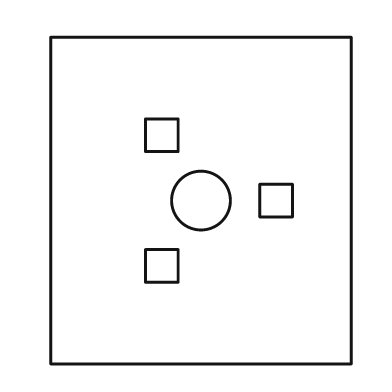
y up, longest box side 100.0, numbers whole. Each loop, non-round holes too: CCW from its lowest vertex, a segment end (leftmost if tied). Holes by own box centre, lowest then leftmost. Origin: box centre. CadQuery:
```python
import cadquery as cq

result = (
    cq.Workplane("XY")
    .moveTo(-46.0, -50.0)
    .lineTo(46.0, -50.0)
    .lineTo(46.0, 50.0)
    .lineTo(-46.0, 50.0)
    .close()
    .moveTo(-17.0, -25.0)
    .lineTo(-7.0, -25.0)
    .lineTo(-7.0, -15.0)
    .lineTo(-17.0, -15.0)
    .close()
    .moveTo(0.0, 0.0)
    .circle(9.0)
    .moveTo(18.0, -5.0)
    .lineTo(28.0, -5.0)
    .lineTo(28.0, 5.0)
    .lineTo(18.0, 5.0)
    .close()
    .moveTo(-17.0, 15.0)
    .lineTo(-7.0, 15.0)
    .lineTo(-7.0, 25.0)
    .lineTo(-17.0, 25.0)
    .close()
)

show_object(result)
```